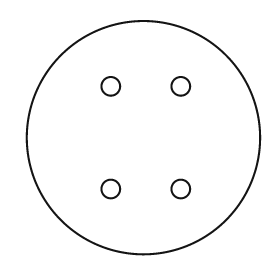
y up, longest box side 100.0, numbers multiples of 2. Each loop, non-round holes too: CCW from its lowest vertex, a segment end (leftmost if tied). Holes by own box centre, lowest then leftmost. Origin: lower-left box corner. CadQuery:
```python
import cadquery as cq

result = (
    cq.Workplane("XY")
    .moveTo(50.0, 50.0)
    .circle(50.0)
    .moveTo(36.0, 28.0)
    .circle(4.0)
    .moveTo(66.0, 28.0)
    .circle(4.0)
    .moveTo(36.0, 72.0)
    .circle(4.0)
    .moveTo(66.0, 72.0)
    .circle(4.0)
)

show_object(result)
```